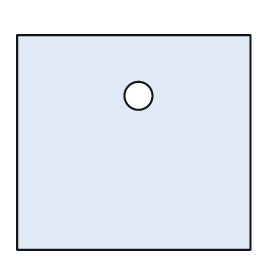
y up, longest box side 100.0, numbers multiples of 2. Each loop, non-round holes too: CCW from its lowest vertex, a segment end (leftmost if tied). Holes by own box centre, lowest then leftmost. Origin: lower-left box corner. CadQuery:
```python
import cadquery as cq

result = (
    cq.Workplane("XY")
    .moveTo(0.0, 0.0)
    .lineTo(100.0, 0.0)
    .lineTo(100.0, 92.0)
    .lineTo(0.0, 92.0)
    .close()
    .moveTo(52.0, 66.0)
    .circle(6.0)
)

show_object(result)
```